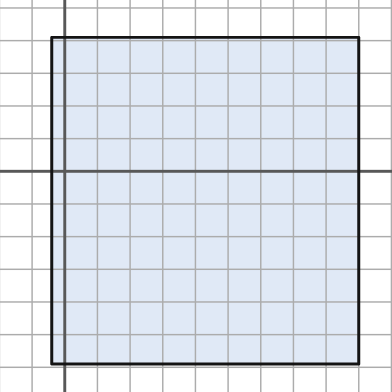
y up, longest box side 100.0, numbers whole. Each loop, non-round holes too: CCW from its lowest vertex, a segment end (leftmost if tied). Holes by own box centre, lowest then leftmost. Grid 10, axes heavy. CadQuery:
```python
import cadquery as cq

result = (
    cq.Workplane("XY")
    .moveTo(-4.0, -59.0)
    .lineTo(90.0, -59.0)
    .lineTo(90.0, 41.0)
    .lineTo(-4.0, 41.0)
    .close()
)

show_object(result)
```